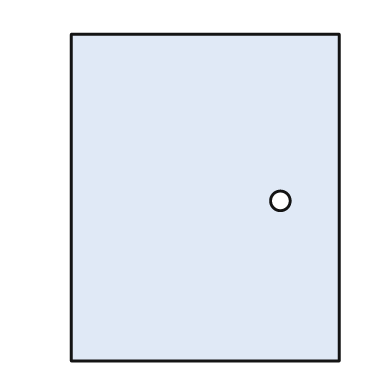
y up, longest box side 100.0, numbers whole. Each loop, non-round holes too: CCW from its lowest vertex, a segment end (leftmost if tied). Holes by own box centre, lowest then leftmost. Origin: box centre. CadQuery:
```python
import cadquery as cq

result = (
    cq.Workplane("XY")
    .moveTo(-41.0, -50.0)
    .lineTo(41.0, -50.0)
    .lineTo(41.0, 50.0)
    .lineTo(-41.0, 50.0)
    .close()
    .moveTo(23.0, -1.0)
    .circle(3.0)
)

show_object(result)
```